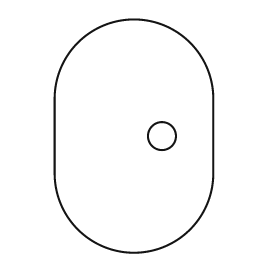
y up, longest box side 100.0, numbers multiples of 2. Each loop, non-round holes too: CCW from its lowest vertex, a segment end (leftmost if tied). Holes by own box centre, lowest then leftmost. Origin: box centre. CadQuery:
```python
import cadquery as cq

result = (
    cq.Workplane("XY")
    .moveTo(-34.0, -16.0)
    .threePointArc((0.0, -50.0), (34.0, -16.0))
    .lineTo(34.0, 16.0)
    .threePointArc((0.0, 50.0), (-34.0, 16.0))
    .close()
    .moveTo(12.0, 0.0)
    .circle(6.0)
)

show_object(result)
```